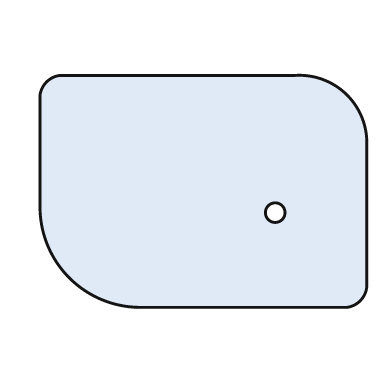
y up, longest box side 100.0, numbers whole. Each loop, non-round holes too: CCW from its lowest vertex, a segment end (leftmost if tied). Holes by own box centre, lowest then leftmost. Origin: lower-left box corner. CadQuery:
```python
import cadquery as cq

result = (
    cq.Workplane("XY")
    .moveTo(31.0, 0.0)
    .lineTo(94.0, 0.0)
    .threePointArc((98.0, 2.0), (100.0, 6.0))
    .lineTo(100.0, 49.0)
    .threePointArc((94.0, 65.0), (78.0, 71.0))
    .lineTo(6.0, 71.0)
    .threePointArc((2.0, 69.0), (0.0, 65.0))
    .lineTo(0.0, 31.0)
    .threePointArc((9.0, 9.0), (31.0, 0.0))
    .close()
    .moveTo(72.0, 29.0)
    .circle(3.0)
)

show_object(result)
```